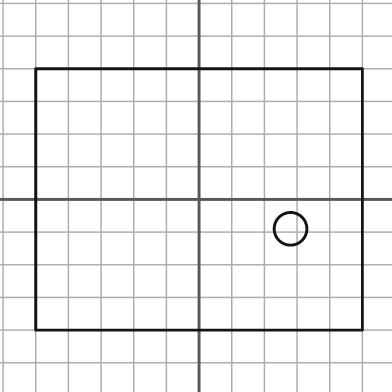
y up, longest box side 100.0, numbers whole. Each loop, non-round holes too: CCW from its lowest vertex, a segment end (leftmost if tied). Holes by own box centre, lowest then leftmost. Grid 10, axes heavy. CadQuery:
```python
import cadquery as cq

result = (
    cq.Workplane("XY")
    .moveTo(-50.0, -40.0)
    .lineTo(50.0, -40.0)
    .lineTo(50.0, 40.0)
    .lineTo(-50.0, 40.0)
    .close()
    .moveTo(28.0, -9.0)
    .circle(5.0)
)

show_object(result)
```